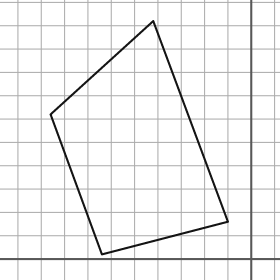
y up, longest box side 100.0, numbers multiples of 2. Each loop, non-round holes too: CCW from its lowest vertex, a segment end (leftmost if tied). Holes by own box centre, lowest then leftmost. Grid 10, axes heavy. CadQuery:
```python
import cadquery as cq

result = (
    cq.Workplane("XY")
    .moveTo(-64.0, 2.0)
    .lineTo(-10.0, 16.0)
    .lineTo(-42.0, 102.0)
    .lineTo(-86.0, 62.0)
    .close()
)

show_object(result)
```